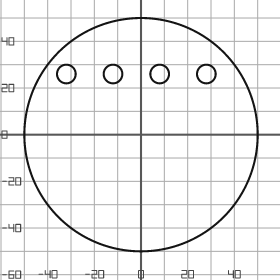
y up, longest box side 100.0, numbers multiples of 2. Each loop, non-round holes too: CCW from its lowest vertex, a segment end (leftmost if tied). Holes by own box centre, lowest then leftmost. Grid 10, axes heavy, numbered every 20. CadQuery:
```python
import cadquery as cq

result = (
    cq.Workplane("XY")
    .moveTo(0.0, 0.0)
    .circle(50.0)
    .moveTo(-32.0, 26.0)
    .circle(4.0)
    .moveTo(-12.0, 26.0)
    .circle(4.0)
    .moveTo(8.0, 26.0)
    .circle(4.0)
    .moveTo(28.0, 26.0)
    .circle(4.0)
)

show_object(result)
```